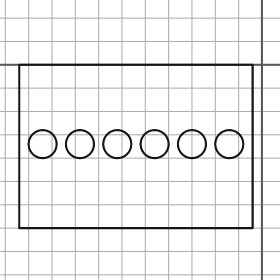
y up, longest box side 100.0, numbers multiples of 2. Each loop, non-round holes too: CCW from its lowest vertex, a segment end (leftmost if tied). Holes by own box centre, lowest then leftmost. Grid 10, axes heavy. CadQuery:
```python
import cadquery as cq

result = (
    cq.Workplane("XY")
    .moveTo(-104.0, -70.0)
    .lineTo(-4.0, -70.0)
    .lineTo(-4.0, 0.0)
    .lineTo(-104.0, 0.0)
    .close()
    .moveTo(-94.0, -34.0)
    .circle(6.0)
    .moveTo(-78.0, -34.0)
    .circle(6.0)
    .moveTo(-62.0, -34.0)
    .circle(6.0)
    .moveTo(-46.0, -34.0)
    .circle(6.0)
    .moveTo(-30.0, -34.0)
    .circle(6.0)
    .moveTo(-14.0, -34.0)
    .circle(6.0)
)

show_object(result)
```